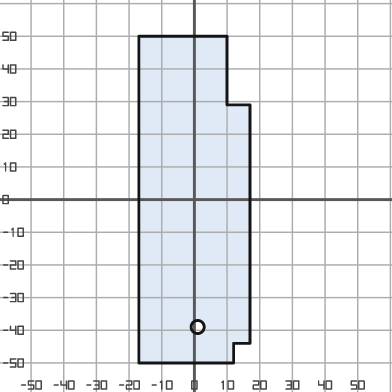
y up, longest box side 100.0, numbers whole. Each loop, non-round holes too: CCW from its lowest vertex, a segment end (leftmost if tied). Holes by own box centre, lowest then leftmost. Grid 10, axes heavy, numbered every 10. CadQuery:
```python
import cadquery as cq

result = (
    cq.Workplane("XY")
    .moveTo(-17.0, -50.0)
    .lineTo(12.0, -50.0)
    .lineTo(12.0, -44.0)
    .lineTo(17.0, -44.0)
    .lineTo(17.0, 29.0)
    .lineTo(10.0, 29.0)
    .lineTo(10.0, 50.0)
    .lineTo(-17.0, 50.0)
    .close()
    .moveTo(1.0, -39.0)
    .circle(2.0)
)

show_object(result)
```